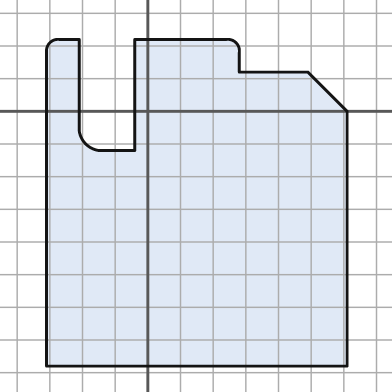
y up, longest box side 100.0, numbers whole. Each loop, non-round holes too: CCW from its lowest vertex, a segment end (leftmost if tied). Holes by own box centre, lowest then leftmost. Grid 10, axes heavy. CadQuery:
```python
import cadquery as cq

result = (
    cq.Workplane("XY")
    .moveTo(-31.0, -78.0)
    .lineTo(61.0, -78.0)
    .lineTo(61.0, 0.0)
    .lineTo(49.0, 12.0)
    .lineTo(28.0, 12.0)
    .lineTo(28.0, 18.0)
    .threePointArc((27.0, 21.0), (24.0, 22.0))
    .lineTo(-4.0, 22.0)
    .lineTo(-4.0, -12.0)
    .lineTo(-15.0, -12.0)
    .threePointArc((-19.0, -10.0), (-21.0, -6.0))
    .lineTo(-21.0, 22.0)
    .lineTo(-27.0, 22.0)
    .threePointArc((-30.0, 21.0), (-31.0, 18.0))
    .close()
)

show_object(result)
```